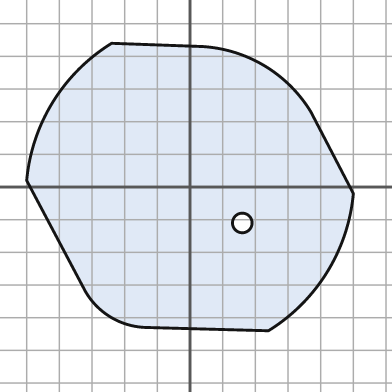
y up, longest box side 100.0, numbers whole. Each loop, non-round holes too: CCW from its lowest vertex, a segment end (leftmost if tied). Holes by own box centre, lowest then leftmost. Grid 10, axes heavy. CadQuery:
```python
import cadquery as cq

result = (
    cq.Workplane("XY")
    .moveTo(24.0, -44.0)
    .threePointArc((42.0, -26.0), (50.0, -2.0))
    .lineTo(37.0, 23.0)
    .threePointArc((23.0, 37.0), (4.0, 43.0))
    .lineTo(-24.0, 44.0)
    .threePointArc((-42.0, 26.0), (-50.0, 2.0))
    .lineTo(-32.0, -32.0)
    .threePointArc((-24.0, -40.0), (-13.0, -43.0))
    .close()
    .moveTo(16.0, -11.0)
    .circle(3.0)
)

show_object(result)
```